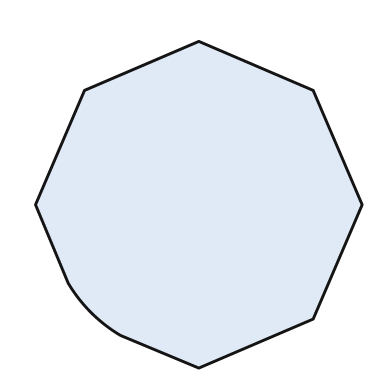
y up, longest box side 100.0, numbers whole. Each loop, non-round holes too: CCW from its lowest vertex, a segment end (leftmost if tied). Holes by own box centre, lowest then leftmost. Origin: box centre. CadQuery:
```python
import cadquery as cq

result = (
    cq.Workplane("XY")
    .moveTo(0.0, -50.0)
    .lineTo(35.0, -35.0)
    .lineTo(50.0, 0.0)
    .lineTo(35.0, 35.0)
    .lineTo(0.0, 50.0)
    .lineTo(-35.0, 35.0)
    .lineTo(-50.0, 0.0)
    .lineTo(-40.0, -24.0)
    .threePointArc((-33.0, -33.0), (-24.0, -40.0))
    .close()
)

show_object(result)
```